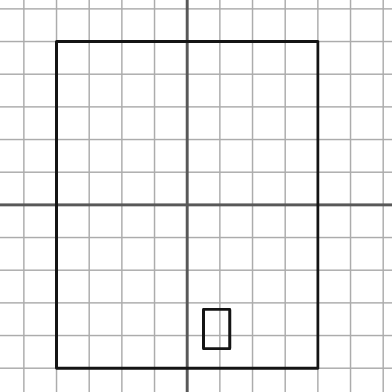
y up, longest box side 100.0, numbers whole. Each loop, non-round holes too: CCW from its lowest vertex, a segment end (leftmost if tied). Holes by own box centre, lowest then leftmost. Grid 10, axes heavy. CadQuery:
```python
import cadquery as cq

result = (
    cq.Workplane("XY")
    .moveTo(-40.0, -50.0)
    .lineTo(40.0, -50.0)
    .lineTo(40.0, 50.0)
    .lineTo(-40.0, 50.0)
    .close()
    .moveTo(5.0, -44.0)
    .lineTo(13.0, -44.0)
    .lineTo(13.0, -32.0)
    .lineTo(5.0, -32.0)
    .close()
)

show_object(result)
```